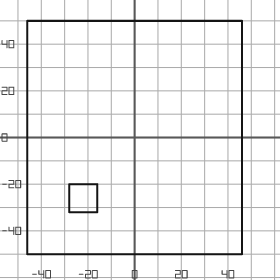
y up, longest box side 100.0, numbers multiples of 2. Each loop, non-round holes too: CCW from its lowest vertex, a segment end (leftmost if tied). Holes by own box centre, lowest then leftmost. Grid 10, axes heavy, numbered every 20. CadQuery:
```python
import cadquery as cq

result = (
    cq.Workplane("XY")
    .moveTo(-46.0, -50.0)
    .lineTo(46.0, -50.0)
    .lineTo(46.0, 50.0)
    .lineTo(-46.0, 50.0)
    .close()
    .moveTo(-28.0, -32.0)
    .lineTo(-16.0, -32.0)
    .lineTo(-16.0, -20.0)
    .lineTo(-28.0, -20.0)
    .close()
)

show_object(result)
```